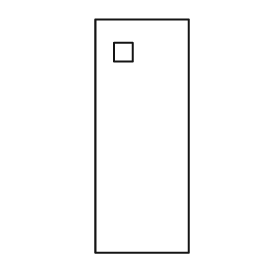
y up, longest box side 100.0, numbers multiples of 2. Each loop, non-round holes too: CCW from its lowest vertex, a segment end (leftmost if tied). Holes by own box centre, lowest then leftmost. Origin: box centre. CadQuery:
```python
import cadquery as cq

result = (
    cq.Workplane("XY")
    .moveTo(-20.0, -50.0)
    .lineTo(20.0, -50.0)
    .lineTo(20.0, 50.0)
    .lineTo(-20.0, 50.0)
    .close()
    .moveTo(-12.0, 32.0)
    .lineTo(-4.0, 32.0)
    .lineTo(-4.0, 40.0)
    .lineTo(-12.0, 40.0)
    .close()
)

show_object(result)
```